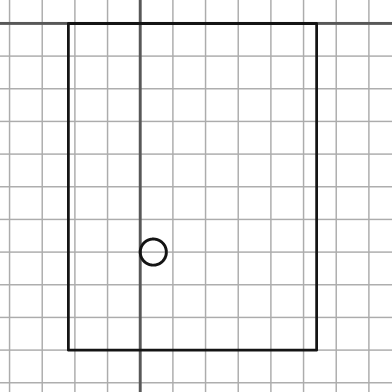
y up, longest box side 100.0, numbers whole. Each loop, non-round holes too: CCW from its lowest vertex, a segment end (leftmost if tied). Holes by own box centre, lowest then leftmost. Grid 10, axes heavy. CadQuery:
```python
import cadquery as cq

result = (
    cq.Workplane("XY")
    .moveTo(-22.0, -100.0)
    .lineTo(54.0, -100.0)
    .lineTo(54.0, 0.0)
    .lineTo(-22.0, 0.0)
    .close()
    .moveTo(4.0, -70.0)
    .circle(4.0)
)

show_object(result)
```